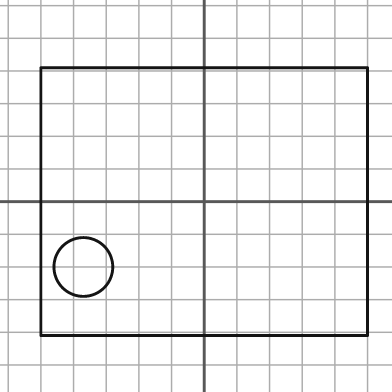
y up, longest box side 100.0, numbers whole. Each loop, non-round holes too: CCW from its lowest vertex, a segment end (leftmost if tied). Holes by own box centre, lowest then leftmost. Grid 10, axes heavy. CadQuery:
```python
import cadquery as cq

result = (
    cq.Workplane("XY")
    .moveTo(-50.0, -41.0)
    .lineTo(50.0, -41.0)
    .lineTo(50.0, 41.0)
    .lineTo(-50.0, 41.0)
    .close()
    .moveTo(-37.0, -20.0)
    .circle(9.0)
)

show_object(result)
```